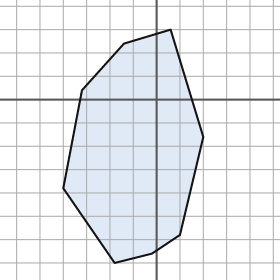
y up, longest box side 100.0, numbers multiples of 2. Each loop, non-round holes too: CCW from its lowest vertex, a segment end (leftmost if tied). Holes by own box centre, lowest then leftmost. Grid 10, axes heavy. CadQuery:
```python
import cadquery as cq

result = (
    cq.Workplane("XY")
    .moveTo(-18.0, -70.0)
    .lineTo(-2.0, -66.0)
    .lineTo(10.0, -58.0)
    .lineTo(20.0, -16.0)
    .lineTo(6.0, 30.0)
    .lineTo(-14.0, 24.0)
    .lineTo(-32.0, 4.0)
    .lineTo(-40.0, -38.0)
    .close()
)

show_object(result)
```